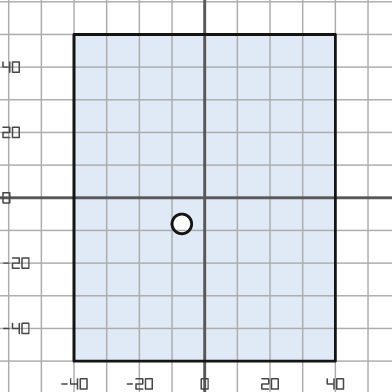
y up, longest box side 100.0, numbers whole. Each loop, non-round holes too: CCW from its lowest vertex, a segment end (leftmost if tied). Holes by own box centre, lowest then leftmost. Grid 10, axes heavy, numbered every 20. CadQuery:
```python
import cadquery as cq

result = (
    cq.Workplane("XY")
    .moveTo(-40.0, -50.0)
    .lineTo(40.0, -50.0)
    .lineTo(40.0, 50.0)
    .lineTo(-40.0, 50.0)
    .close()
    .moveTo(-7.0, -8.0)
    .circle(3.0)
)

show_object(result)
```